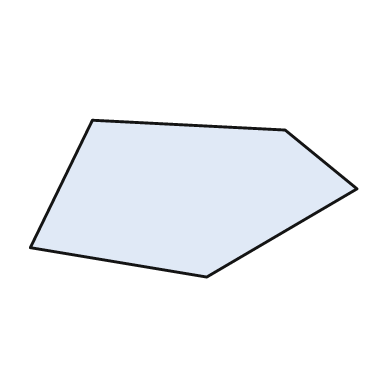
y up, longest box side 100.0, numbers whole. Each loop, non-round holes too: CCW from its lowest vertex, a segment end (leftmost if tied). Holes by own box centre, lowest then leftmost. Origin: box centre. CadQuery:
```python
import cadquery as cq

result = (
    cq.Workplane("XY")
    .moveTo(4.0, -24.0)
    .lineTo(50.0, 3.0)
    .lineTo(28.0, 21.0)
    .lineTo(-31.0, 24.0)
    .lineTo(-50.0, -15.0)
    .close()
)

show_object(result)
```